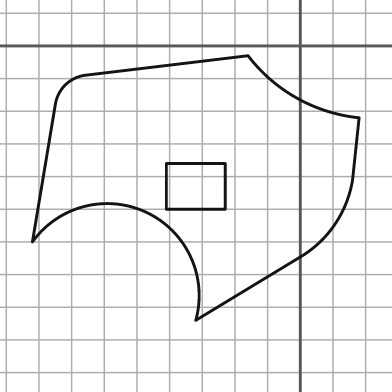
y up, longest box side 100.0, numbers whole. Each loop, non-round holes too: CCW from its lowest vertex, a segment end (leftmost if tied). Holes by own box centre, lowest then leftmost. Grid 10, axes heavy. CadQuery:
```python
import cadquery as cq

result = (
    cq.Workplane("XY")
    .moveTo(-32.0, -84.0)
    .lineTo(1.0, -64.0)
    .threePointArc((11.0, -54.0), (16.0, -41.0))
    .lineTo(18.0, -22.0)
    .threePointArc((-1.0, -16.0), (-16.0, -3.0))
    .lineTo(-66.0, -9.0)
    .threePointArc((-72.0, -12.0), (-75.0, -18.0))
    .lineTo(-82.0, -60.0)
    .threePointArc((-47.0, -51.0), (-32.0, -84.0))
    .close()
    .moveTo(-41.0, -50.0)
    .lineTo(-23.0, -50.0)
    .lineTo(-23.0, -36.0)
    .lineTo(-41.0, -36.0)
    .close()
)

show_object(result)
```